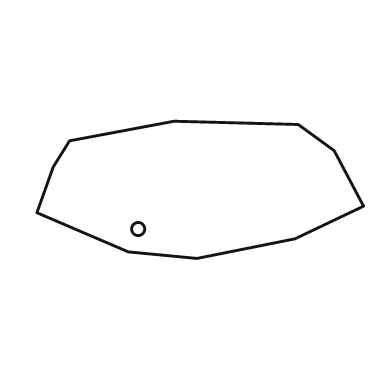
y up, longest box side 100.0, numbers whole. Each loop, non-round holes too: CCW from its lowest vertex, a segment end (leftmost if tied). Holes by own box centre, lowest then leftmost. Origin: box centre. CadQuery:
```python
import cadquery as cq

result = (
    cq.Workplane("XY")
    .moveTo(-1.0, -21.0)
    .lineTo(29.0, -15.0)
    .lineTo(50.0, -5.0)
    .lineTo(41.0, 12.0)
    .lineTo(30.0, 20.0)
    .lineTo(-8.0, 21.0)
    .lineTo(-40.0, 15.0)
    .lineTo(-45.0, 7.0)
    .lineTo(-50.0, -7.0)
    .lineTo(-22.0, -19.0)
    .close()
    .moveTo(-19.0, -12.0)
    .circle(2.0)
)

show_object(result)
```